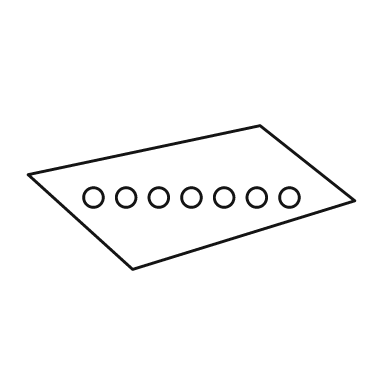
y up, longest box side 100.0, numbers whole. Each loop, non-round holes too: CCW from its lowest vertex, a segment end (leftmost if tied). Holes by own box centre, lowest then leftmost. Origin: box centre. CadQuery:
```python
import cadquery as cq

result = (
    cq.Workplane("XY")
    .moveTo(-18.0, -22.0)
    .lineTo(50.0, -1.0)
    .lineTo(21.0, 22.0)
    .lineTo(-50.0, 7.0)
    .close()
    .moveTo(-30.0, 0.0)
    .circle(3.0)
    .moveTo(-20.0, 0.0)
    .circle(3.0)
    .moveTo(-10.0, 0.0)
    .circle(3.0)
    .moveTo(0.0, 0.0)
    .circle(3.0)
    .moveTo(10.0, 0.0)
    .circle(3.0)
    .moveTo(20.0, 0.0)
    .circle(3.0)
    .moveTo(30.0, 0.0)
    .circle(3.0)
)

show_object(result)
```